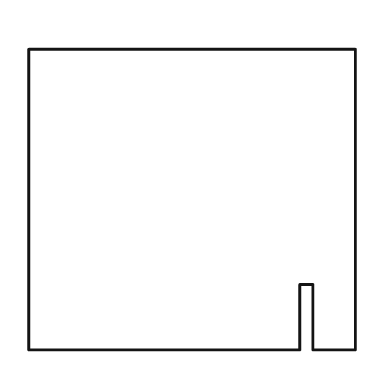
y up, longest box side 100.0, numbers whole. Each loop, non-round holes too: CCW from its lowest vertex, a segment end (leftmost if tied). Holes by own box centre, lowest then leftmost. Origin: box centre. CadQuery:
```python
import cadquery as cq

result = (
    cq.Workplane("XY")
    .moveTo(-50.0, -46.0)
    .lineTo(33.0, -46.0)
    .lineTo(33.0, -26.0)
    .lineTo(37.0, -26.0)
    .lineTo(37.0, -46.0)
    .lineTo(50.0, -46.0)
    .lineTo(50.0, 46.0)
    .lineTo(-50.0, 46.0)
    .close()
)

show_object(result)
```